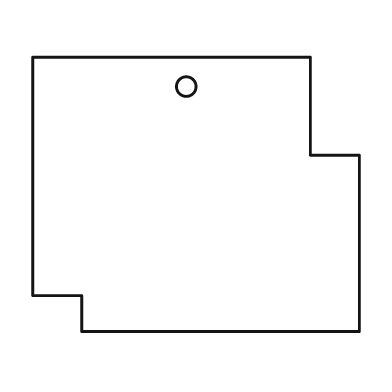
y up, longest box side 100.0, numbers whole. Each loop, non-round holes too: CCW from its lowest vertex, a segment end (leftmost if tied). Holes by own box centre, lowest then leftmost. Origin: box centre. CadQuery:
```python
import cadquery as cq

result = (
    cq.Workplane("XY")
    .moveTo(-35.0, -42.0)
    .lineTo(50.0, -42.0)
    .lineTo(50.0, 12.0)
    .lineTo(35.0, 12.0)
    .lineTo(35.0, 42.0)
    .lineTo(-50.0, 42.0)
    .lineTo(-50.0, -31.0)
    .lineTo(-35.0, -31.0)
    .close()
    .moveTo(-3.0, 33.0)
    .circle(3.0)
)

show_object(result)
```